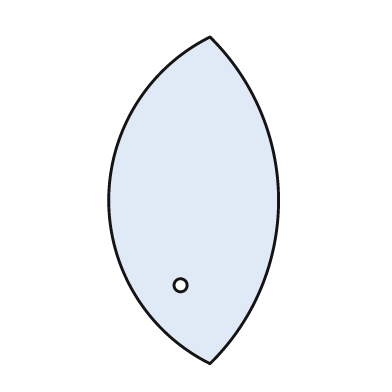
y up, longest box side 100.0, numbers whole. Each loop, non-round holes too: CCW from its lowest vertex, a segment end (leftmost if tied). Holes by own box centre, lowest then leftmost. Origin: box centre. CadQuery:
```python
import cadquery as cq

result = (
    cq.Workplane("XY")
    .moveTo(5.0, -50.0)
    .threePointArc((26.0, 0.0), (5.0, 50.0))
    .threePointArc((-26.0, 0.0), (5.0, -50.0))
    .close()
    .moveTo(-4.0, -26.0)
    .circle(2.0)
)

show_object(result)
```